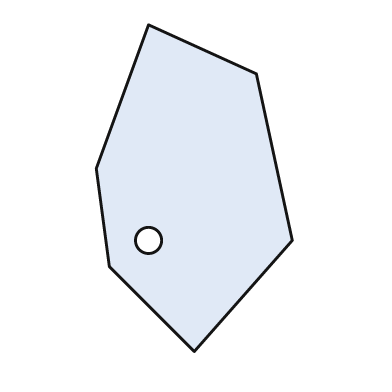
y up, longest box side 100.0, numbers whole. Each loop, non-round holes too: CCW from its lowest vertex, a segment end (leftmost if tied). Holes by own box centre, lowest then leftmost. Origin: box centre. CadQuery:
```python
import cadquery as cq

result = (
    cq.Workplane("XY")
    .moveTo(0.0, -50.0)
    .lineTo(30.0, -16.0)
    .lineTo(19.0, 35.0)
    .lineTo(-14.0, 50.0)
    .lineTo(-30.0, 6.0)
    .lineTo(-26.0, -24.0)
    .close()
    .moveTo(-14.0, -16.0)
    .circle(4.0)
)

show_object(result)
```